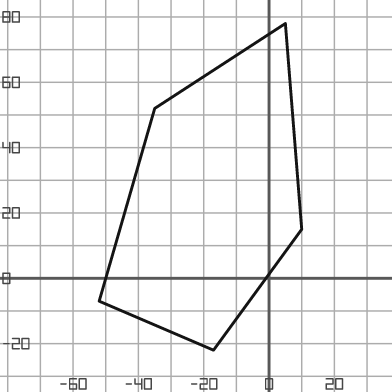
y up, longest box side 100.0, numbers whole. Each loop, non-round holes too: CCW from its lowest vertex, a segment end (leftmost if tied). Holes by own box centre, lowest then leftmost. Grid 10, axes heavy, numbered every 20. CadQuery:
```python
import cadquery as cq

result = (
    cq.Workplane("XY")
    .moveTo(-17.0, -22.0)
    .lineTo(10.0, 15.0)
    .lineTo(5.0, 78.0)
    .lineTo(-35.0, 52.0)
    .lineTo(-52.0, -7.0)
    .close()
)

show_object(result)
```